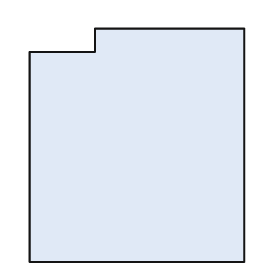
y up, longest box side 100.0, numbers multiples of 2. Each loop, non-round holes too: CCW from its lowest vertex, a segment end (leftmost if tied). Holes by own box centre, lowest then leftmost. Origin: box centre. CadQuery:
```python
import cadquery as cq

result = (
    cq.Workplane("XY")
    .moveTo(-46.0, -50.0)
    .lineTo(46.0, -50.0)
    .lineTo(46.0, 50.0)
    .lineTo(-18.0, 50.0)
    .lineTo(-18.0, 40.0)
    .lineTo(-46.0, 40.0)
    .close()
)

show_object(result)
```